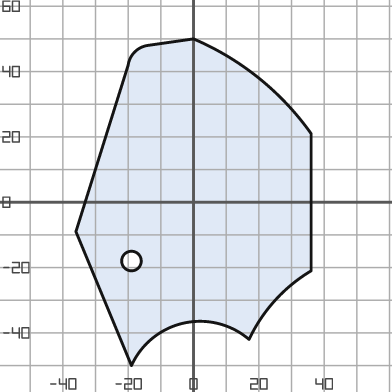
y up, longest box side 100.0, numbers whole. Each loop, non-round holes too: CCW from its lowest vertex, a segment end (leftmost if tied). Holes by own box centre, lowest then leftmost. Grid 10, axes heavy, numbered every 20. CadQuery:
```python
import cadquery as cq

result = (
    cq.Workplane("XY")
    .moveTo(-19.0, -50.0)
    .threePointArc((-3.0, -37.0), (17.0, -42.0))
    .threePointArc((25.0, -30.0), (36.0, -21.0))
    .lineTo(36.0, 21.0)
    .threePointArc((20.0, 38.0), (0.0, 50.0))
    .lineTo(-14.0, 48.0)
    .threePointArc((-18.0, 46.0), (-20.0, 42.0))
    .lineTo(-36.0, -9.0)
    .close()
    .moveTo(-19.0, -18.0)
    .circle(3.0)
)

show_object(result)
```